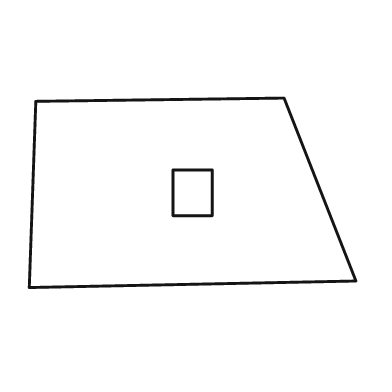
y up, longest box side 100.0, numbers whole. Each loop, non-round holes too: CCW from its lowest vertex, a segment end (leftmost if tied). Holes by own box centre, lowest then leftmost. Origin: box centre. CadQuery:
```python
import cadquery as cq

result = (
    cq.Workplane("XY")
    .moveTo(-50.0, -29.0)
    .lineTo(50.0, -27.0)
    .lineTo(28.0, 29.0)
    .lineTo(-48.0, 28.0)
    .close()
    .moveTo(-6.0, -7.0)
    .lineTo(6.0, -7.0)
    .lineTo(6.0, 7.0)
    .lineTo(-6.0, 7.0)
    .close()
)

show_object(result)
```